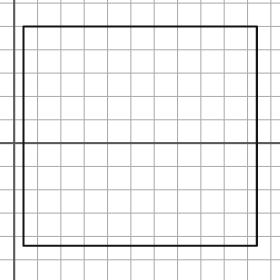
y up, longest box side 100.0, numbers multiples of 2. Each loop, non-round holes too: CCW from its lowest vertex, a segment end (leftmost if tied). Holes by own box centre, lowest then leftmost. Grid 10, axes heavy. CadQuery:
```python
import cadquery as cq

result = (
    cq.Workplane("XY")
    .moveTo(4.0, -44.0)
    .lineTo(104.0, -44.0)
    .lineTo(104.0, 50.0)
    .lineTo(4.0, 50.0)
    .close()
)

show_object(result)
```